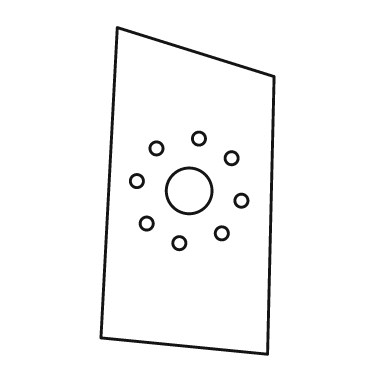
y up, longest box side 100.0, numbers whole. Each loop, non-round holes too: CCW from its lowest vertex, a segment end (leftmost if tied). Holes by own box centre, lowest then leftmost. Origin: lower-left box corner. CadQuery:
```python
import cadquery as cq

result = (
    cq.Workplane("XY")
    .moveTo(51.0, 0.0)
    .lineTo(53.0, 85.0)
    .lineTo(5.0, 100.0)
    .lineTo(0.0, 5.0)
    .close()
    .moveTo(24.0, 34.0)
    .circle(2.0)
    .moveTo(37.0, 37.0)
    .circle(2.0)
    .moveTo(14.0, 40.0)
    .circle(2.0)
    .moveTo(43.0, 47.0)
    .circle(2.0)
    .moveTo(27.0, 50.0)
    .circle(7.0)
    .moveTo(11.0, 53.0)
    .circle(2.0)
    .moveTo(40.0, 60.0)
    .circle(2.0)
    .moveTo(17.0, 63.0)
    .circle(2.0)
    .moveTo(30.0, 66.0)
    .circle(2.0)
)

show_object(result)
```